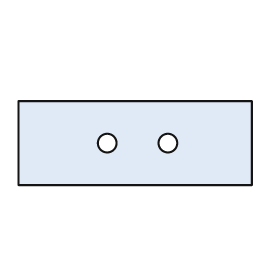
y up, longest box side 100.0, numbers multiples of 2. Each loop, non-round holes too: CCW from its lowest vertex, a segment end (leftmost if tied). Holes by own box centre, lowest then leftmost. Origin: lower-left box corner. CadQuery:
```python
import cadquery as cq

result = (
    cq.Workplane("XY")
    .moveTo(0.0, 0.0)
    .lineTo(100.0, 0.0)
    .lineTo(100.0, 36.0)
    .lineTo(0.0, 36.0)
    .close()
    .moveTo(38.0, 18.0)
    .circle(4.0)
    .moveTo(64.0, 18.0)
    .circle(4.0)
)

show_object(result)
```